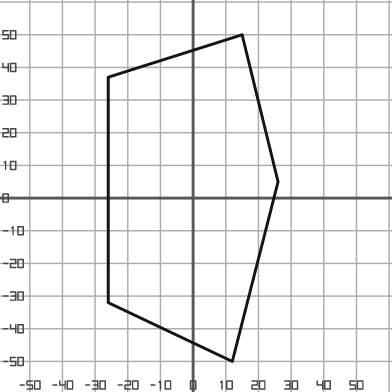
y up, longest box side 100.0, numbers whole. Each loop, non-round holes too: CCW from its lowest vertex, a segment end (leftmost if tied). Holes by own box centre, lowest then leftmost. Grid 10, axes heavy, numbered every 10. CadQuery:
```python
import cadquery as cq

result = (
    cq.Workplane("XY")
    .moveTo(12.0, -50.0)
    .lineTo(26.0, 5.0)
    .lineTo(15.0, 50.0)
    .lineTo(-26.0, 37.0)
    .lineTo(-26.0, -32.0)
    .close()
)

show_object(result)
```